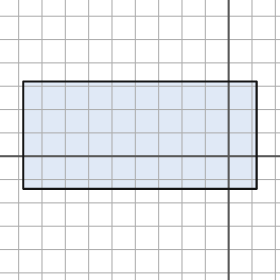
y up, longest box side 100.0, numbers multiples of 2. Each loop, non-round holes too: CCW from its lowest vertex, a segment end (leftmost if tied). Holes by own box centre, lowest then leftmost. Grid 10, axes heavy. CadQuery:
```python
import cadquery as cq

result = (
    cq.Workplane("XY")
    .moveTo(-88.0, -14.0)
    .lineTo(12.0, -14.0)
    .lineTo(12.0, 32.0)
    .lineTo(-88.0, 32.0)
    .close()
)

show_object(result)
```